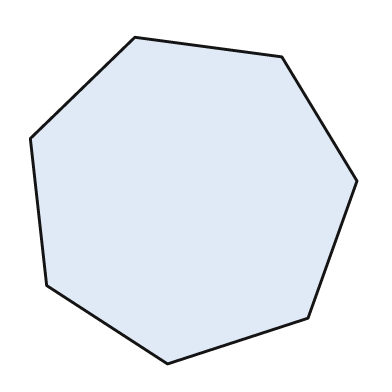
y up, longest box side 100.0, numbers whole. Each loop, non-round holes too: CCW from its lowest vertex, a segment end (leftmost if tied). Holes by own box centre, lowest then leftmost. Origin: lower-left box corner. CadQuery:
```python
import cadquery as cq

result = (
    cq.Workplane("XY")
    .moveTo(42.0, 0.0)
    .lineTo(85.0, 14.0)
    .lineTo(100.0, 56.0)
    .lineTo(77.0, 94.0)
    .lineTo(32.0, 100.0)
    .lineTo(0.0, 69.0)
    .lineTo(5.0, 24.0)
    .close()
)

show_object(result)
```